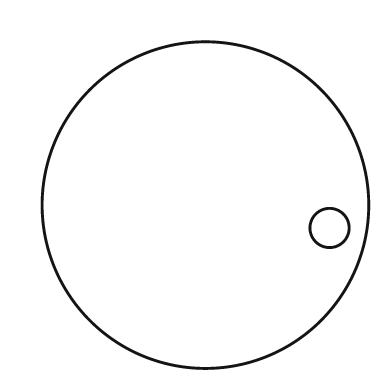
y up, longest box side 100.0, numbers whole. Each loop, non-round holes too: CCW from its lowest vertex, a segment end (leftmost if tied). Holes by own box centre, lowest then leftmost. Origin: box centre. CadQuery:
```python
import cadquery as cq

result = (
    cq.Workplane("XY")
    .moveTo(0.0, 0.0)
    .circle(50.0)
    .moveTo(38.0, -7.0)
    .circle(6.0)
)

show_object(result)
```